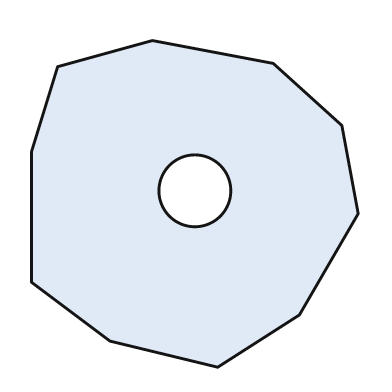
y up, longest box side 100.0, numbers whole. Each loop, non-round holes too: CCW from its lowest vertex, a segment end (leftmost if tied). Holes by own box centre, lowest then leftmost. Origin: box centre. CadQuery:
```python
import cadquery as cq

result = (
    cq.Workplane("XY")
    .moveTo(7.0, -50.0)
    .lineTo(32.0, -34.0)
    .lineTo(50.0, -3.0)
    .lineTo(45.0, 24.0)
    .lineTo(24.0, 43.0)
    .lineTo(-13.0, 50.0)
    .lineTo(-42.0, 42.0)
    .lineTo(-50.0, 16.0)
    .lineTo(-50.0, -24.0)
    .lineTo(-26.0, -42.0)
    .close()
    .moveTo(0.0, 4.0)
    .circle(11.0)
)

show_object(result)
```